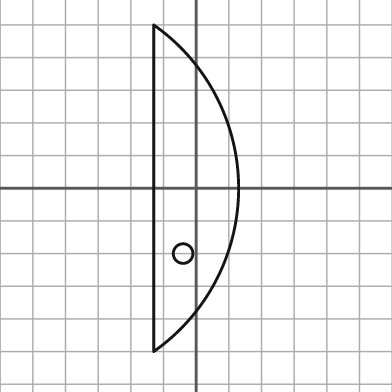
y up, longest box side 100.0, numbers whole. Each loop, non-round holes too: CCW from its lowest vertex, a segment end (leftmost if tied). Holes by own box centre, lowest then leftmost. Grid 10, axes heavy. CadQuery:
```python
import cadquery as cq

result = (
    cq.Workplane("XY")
    .moveTo(-13.0, -50.0)
    .threePointArc((13.0, 0.0), (-13.0, 50.0))
    .close()
    .moveTo(-4.0, -20.0)
    .circle(3.0)
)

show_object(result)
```